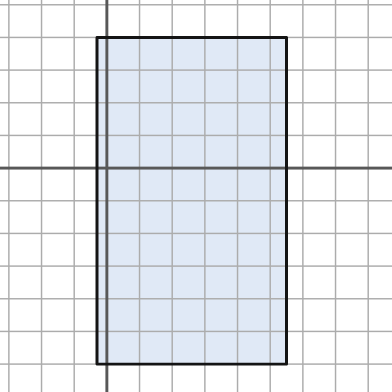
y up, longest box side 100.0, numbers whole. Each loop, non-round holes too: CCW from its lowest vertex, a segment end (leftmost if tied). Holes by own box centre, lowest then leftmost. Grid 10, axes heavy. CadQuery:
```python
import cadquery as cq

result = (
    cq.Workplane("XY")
    .moveTo(-3.0, -60.0)
    .lineTo(55.0, -60.0)
    .lineTo(55.0, 40.0)
    .lineTo(-3.0, 40.0)
    .close()
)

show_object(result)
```